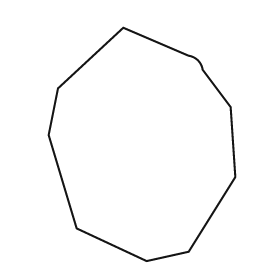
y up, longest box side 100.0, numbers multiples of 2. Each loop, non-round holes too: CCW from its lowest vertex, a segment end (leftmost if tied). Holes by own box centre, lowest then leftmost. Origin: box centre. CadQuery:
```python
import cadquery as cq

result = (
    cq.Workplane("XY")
    .moveTo(2.0, -50.0)
    .lineTo(20.0, -46.0)
    .lineTo(40.0, -14.0)
    .lineTo(38.0, 16.0)
    .lineTo(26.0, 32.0)
    .threePointArc((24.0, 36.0), (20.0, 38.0))
    .lineTo(-8.0, 50.0)
    .lineTo(-36.0, 24.0)
    .lineTo(-40.0, 4.0)
    .lineTo(-28.0, -36.0)
    .close()
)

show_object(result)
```